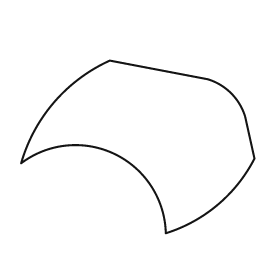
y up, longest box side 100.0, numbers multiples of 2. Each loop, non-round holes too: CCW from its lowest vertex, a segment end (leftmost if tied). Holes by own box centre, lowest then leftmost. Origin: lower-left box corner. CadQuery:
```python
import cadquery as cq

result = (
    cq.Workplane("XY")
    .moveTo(62.0, 0.0)
    .threePointArc((84.0, 12.0), (100.0, 32.0))
    .lineTo(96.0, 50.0)
    .threePointArc((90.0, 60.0), (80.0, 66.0))
    .lineTo(38.0, 74.0)
    .threePointArc((14.0, 56.0), (0.0, 30.0))
    .threePointArc((40.0, 34.0), (62.0, 0.0))
    .close()
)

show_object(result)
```